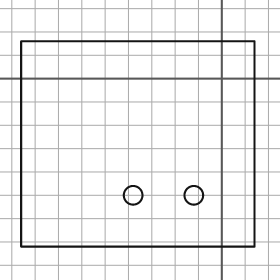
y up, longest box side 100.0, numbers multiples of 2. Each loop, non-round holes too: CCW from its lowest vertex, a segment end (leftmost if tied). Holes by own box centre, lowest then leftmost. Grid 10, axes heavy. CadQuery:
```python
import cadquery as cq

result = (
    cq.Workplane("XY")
    .moveTo(-86.0, -72.0)
    .lineTo(14.0, -72.0)
    .lineTo(14.0, 16.0)
    .lineTo(-86.0, 16.0)
    .close()
    .moveTo(-38.0, -50.0)
    .circle(4.0)
    .moveTo(-12.0, -50.0)
    .circle(4.0)
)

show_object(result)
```